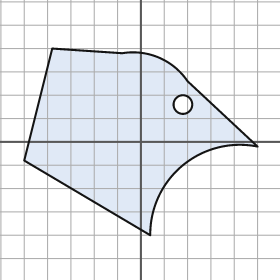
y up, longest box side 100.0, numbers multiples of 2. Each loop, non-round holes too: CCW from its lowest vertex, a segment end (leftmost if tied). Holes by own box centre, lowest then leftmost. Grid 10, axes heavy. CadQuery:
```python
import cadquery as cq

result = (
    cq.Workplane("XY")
    .moveTo(4.0, -40.0)
    .threePointArc((18.0, -10.0), (50.0, -2.0))
    .lineTo(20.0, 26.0)
    .threePointArc((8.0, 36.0), (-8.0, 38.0))
    .lineTo(-38.0, 40.0)
    .lineTo(-50.0, -8.0)
    .close()
    .moveTo(18.0, 16.0)
    .circle(4.0)
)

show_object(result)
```